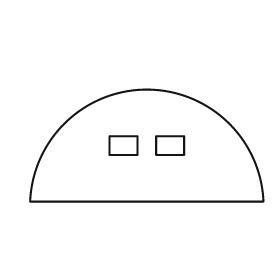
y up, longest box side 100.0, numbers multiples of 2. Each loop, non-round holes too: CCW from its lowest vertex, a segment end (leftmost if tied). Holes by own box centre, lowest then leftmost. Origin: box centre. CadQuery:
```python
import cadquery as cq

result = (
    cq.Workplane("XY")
    .moveTo(-50.0, -24.0)
    .lineTo(50.0, -24.0)
    .threePointArc((0.0, 24.0), (-50.0, -24.0))
    .close()
    .moveTo(-16.0, -4.0)
    .lineTo(-4.0, -4.0)
    .lineTo(-4.0, 4.0)
    .lineTo(-16.0, 4.0)
    .close()
    .moveTo(4.0, -4.0)
    .lineTo(16.0, -4.0)
    .lineTo(16.0, 4.0)
    .lineTo(4.0, 4.0)
    .close()
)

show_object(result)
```